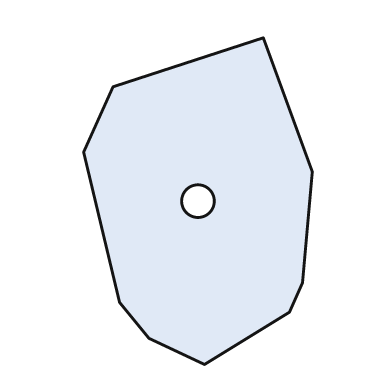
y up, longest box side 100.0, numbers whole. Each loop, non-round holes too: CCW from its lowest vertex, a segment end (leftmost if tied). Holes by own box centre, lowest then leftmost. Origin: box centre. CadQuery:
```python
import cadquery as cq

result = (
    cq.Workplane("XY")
    .moveTo(2.0, -50.0)
    .lineTo(28.0, -34.0)
    .lineTo(32.0, -25.0)
    .lineTo(35.0, 9.0)
    .lineTo(20.0, 50.0)
    .lineTo(-26.0, 35.0)
    .lineTo(-35.0, 15.0)
    .lineTo(-24.0, -31.0)
    .lineTo(-15.0, -42.0)
    .close()
    .moveTo(0.0, 0.0)
    .circle(5.0)
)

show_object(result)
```